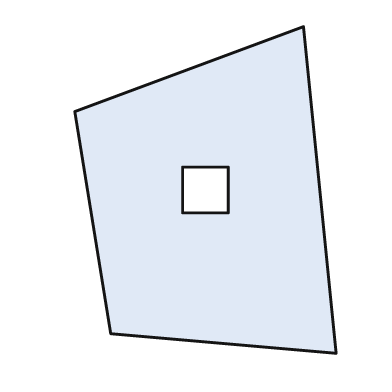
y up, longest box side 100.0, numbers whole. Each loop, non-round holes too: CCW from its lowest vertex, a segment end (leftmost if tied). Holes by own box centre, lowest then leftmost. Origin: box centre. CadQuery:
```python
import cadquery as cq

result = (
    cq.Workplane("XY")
    .moveTo(40.0, -50.0)
    .lineTo(30.0, 50.0)
    .lineTo(-40.0, 24.0)
    .lineTo(-29.0, -44.0)
    .close()
    .moveTo(-7.0, -7.0)
    .lineTo(7.0, -7.0)
    .lineTo(7.0, 7.0)
    .lineTo(-7.0, 7.0)
    .close()
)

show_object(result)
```